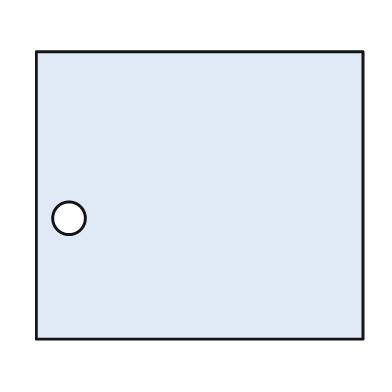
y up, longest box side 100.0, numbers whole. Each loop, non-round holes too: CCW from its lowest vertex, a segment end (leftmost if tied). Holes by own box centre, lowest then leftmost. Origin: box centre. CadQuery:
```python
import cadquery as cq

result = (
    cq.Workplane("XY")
    .moveTo(-50.0, -44.0)
    .lineTo(50.0, -44.0)
    .lineTo(50.0, 44.0)
    .lineTo(-50.0, 44.0)
    .close()
    .moveTo(-40.0, -7.0)
    .circle(5.0)
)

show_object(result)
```